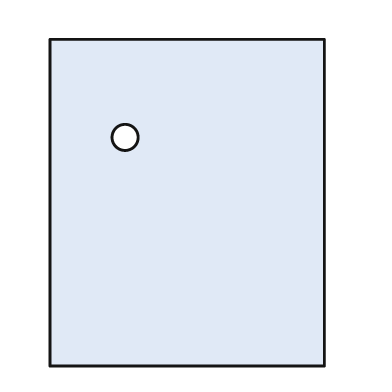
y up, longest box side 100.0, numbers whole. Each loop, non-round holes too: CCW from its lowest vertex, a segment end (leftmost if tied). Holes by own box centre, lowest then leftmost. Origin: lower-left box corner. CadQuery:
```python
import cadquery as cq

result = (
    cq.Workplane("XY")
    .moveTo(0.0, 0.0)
    .lineTo(84.0, 0.0)
    .lineTo(84.0, 100.0)
    .lineTo(0.0, 100.0)
    .close()
    .moveTo(23.0, 70.0)
    .circle(4.0)
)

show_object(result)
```